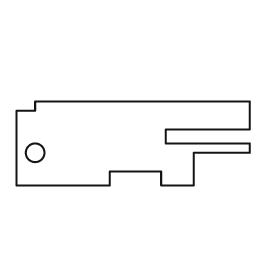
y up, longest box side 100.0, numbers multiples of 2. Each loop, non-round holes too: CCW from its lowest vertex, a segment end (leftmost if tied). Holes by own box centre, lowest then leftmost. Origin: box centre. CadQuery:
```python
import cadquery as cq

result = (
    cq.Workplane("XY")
    .moveTo(-50.0, -18.0)
    .lineTo(-10.0, -18.0)
    .lineTo(-10.0, -12.0)
    .lineTo(12.0, -12.0)
    .lineTo(12.0, -18.0)
    .lineTo(26.0, -18.0)
    .lineTo(26.0, -4.0)
    .lineTo(50.0, -4.0)
    .lineTo(50.0, 0.0)
    .lineTo(14.0, 0.0)
    .lineTo(14.0, 6.0)
    .lineTo(50.0, 6.0)
    .lineTo(50.0, 18.0)
    .lineTo(-42.0, 18.0)
    .lineTo(-42.0, 14.0)
    .lineTo(-50.0, 14.0)
    .close()
    .moveTo(-42.0, -4.0)
    .circle(4.0)
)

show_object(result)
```